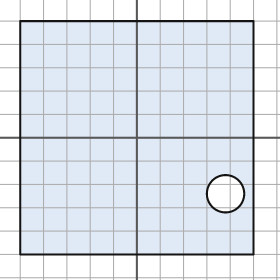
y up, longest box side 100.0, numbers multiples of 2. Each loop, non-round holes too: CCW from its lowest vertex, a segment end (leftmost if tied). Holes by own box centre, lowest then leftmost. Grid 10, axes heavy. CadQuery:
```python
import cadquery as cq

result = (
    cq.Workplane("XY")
    .moveTo(-50.0, -50.0)
    .lineTo(50.0, -50.0)
    .lineTo(50.0, 50.0)
    .lineTo(-50.0, 50.0)
    .close()
    .moveTo(38.0, -24.0)
    .circle(8.0)
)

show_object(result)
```